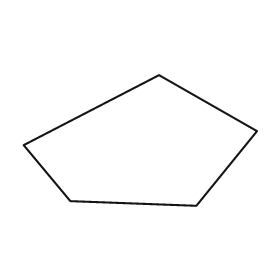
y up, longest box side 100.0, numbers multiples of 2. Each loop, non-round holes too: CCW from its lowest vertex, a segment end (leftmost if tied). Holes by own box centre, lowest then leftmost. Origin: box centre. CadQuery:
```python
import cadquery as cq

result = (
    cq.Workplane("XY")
    .moveTo(24.0, -28.0)
    .lineTo(50.0, 4.0)
    .lineTo(8.0, 28.0)
    .lineTo(-50.0, -2.0)
    .lineTo(-30.0, -26.0)
    .close()
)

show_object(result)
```